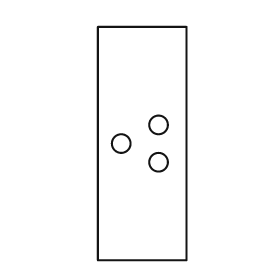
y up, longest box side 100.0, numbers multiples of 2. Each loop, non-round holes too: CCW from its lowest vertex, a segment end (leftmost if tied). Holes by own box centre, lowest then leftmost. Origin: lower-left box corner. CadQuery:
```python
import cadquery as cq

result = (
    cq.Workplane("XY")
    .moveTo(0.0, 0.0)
    .lineTo(38.0, 0.0)
    .lineTo(38.0, 100.0)
    .lineTo(0.0, 100.0)
    .close()
    .moveTo(26.0, 42.0)
    .circle(4.0)
    .moveTo(10.0, 50.0)
    .circle(4.0)
    .moveTo(26.0, 58.0)
    .circle(4.0)
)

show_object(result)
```